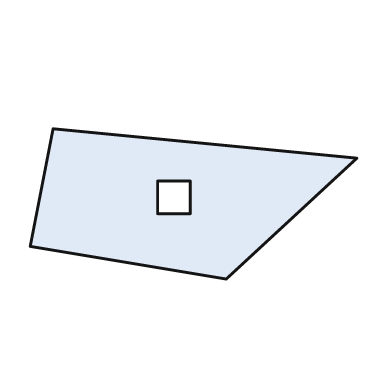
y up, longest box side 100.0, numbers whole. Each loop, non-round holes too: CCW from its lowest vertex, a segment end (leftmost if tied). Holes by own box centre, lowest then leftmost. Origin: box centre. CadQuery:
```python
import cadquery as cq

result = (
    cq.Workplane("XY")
    .moveTo(10.0, -23.0)
    .lineTo(50.0, 14.0)
    .lineTo(-43.0, 23.0)
    .lineTo(-50.0, -13.0)
    .close()
    .moveTo(-11.0, -3.0)
    .lineTo(-1.0, -3.0)
    .lineTo(-1.0, 7.0)
    .lineTo(-11.0, 7.0)
    .close()
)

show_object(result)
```